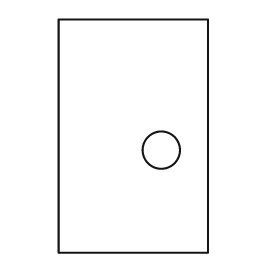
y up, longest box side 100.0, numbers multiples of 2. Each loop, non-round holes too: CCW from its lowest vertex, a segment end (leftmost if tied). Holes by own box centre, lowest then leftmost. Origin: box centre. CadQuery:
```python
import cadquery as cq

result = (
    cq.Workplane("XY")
    .moveTo(-32.0, -50.0)
    .lineTo(32.0, -50.0)
    .lineTo(32.0, 50.0)
    .lineTo(-32.0, 50.0)
    .close()
    .moveTo(12.0, -6.0)
    .circle(8.0)
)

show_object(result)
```